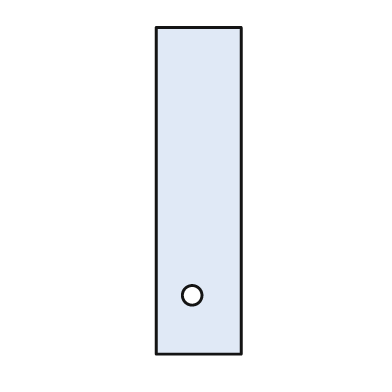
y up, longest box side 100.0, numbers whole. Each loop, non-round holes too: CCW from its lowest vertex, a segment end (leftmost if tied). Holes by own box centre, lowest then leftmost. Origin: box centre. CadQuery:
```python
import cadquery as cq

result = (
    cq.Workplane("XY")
    .moveTo(-13.0, -50.0)
    .lineTo(13.0, -50.0)
    .lineTo(13.0, 50.0)
    .lineTo(-13.0, 50.0)
    .close()
    .moveTo(-2.0, -32.0)
    .circle(3.0)
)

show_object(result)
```